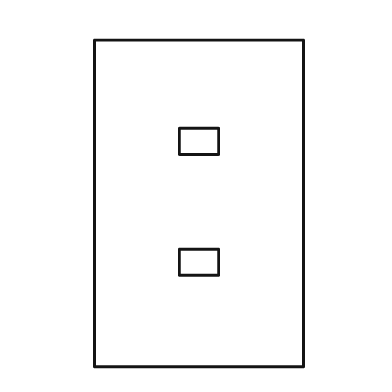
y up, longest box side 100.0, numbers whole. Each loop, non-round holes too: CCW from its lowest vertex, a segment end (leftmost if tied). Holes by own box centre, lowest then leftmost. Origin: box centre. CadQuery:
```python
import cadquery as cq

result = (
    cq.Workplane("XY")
    .moveTo(-32.0, -50.0)
    .lineTo(32.0, -50.0)
    .lineTo(32.0, 50.0)
    .lineTo(-32.0, 50.0)
    .close()
    .moveTo(-6.0, -22.0)
    .lineTo(6.0, -22.0)
    .lineTo(6.0, -14.0)
    .lineTo(-6.0, -14.0)
    .close()
    .moveTo(-6.0, 15.0)
    .lineTo(6.0, 15.0)
    .lineTo(6.0, 23.0)
    .lineTo(-6.0, 23.0)
    .close()
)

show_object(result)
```